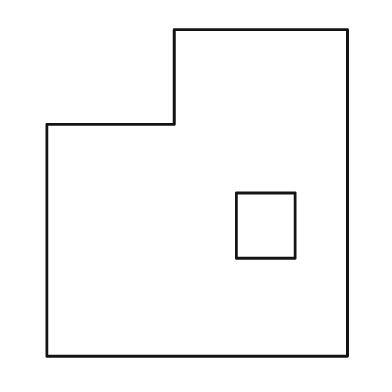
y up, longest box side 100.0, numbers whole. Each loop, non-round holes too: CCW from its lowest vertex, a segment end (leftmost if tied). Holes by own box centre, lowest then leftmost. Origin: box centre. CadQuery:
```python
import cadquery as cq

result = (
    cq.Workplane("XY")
    .moveTo(-46.0, -50.0)
    .lineTo(46.0, -50.0)
    .lineTo(46.0, 50.0)
    .lineTo(-7.0, 50.0)
    .lineTo(-7.0, 21.0)
    .lineTo(-46.0, 21.0)
    .close()
    .moveTo(12.0, -20.0)
    .lineTo(30.0, -20.0)
    .lineTo(30.0, 0.0)
    .lineTo(12.0, 0.0)
    .close()
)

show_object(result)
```